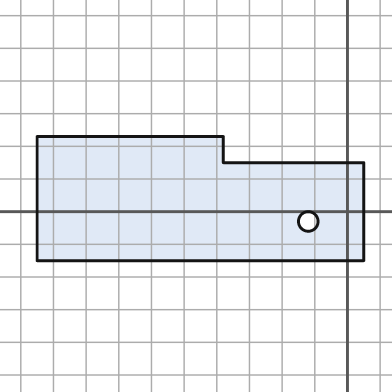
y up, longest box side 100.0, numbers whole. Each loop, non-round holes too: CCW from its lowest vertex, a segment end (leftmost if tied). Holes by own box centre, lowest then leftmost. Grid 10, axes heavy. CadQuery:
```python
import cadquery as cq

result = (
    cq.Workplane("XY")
    .moveTo(-95.0, -15.0)
    .lineTo(5.0, -15.0)
    .lineTo(5.0, 15.0)
    .lineTo(-38.0, 15.0)
    .lineTo(-38.0, 23.0)
    .lineTo(-95.0, 23.0)
    .close()
    .moveTo(-12.0, -3.0)
    .circle(3.0)
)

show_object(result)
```